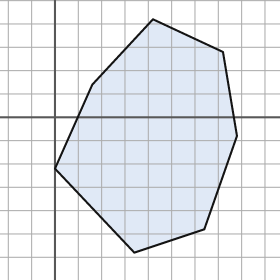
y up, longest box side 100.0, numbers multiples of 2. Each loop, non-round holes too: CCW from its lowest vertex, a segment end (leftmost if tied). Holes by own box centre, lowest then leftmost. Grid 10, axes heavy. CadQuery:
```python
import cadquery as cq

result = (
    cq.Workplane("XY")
    .moveTo(34.0, -58.0)
    .lineTo(64.0, -48.0)
    .lineTo(78.0, -8.0)
    .lineTo(72.0, 28.0)
    .lineTo(42.0, 42.0)
    .lineTo(16.0, 14.0)
    .lineTo(0.0, -22.0)
    .close()
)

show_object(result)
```